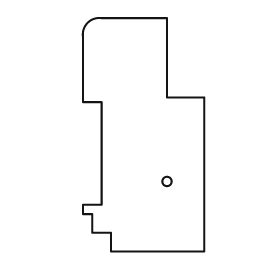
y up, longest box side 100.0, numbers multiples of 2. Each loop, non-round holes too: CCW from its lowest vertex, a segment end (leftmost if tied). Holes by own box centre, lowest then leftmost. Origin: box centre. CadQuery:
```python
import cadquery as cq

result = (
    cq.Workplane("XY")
    .moveTo(-14.0, -50.0)
    .lineTo(26.0, -50.0)
    .lineTo(26.0, 16.0)
    .lineTo(10.0, 16.0)
    .lineTo(10.0, 50.0)
    .lineTo(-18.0, 50.0)
    .threePointArc((-24.0, 48.0), (-26.0, 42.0))
    .lineTo(-26.0, 14.0)
    .lineTo(-18.0, 14.0)
    .lineTo(-18.0, -30.0)
    .lineTo(-26.0, -30.0)
    .lineTo(-26.0, -34.0)
    .lineTo(-22.0, -34.0)
    .lineTo(-22.0, -42.0)
    .lineTo(-14.0, -42.0)
    .close()
    .moveTo(10.0, -20.0)
    .circle(2.0)
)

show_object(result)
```